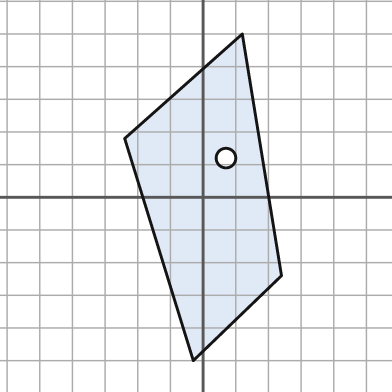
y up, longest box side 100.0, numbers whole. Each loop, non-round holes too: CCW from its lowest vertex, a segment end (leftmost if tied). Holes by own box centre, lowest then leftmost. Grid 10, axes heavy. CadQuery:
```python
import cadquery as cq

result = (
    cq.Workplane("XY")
    .moveTo(-3.0, -50.0)
    .lineTo(24.0, -24.0)
    .lineTo(12.0, 50.0)
    .lineTo(-24.0, 18.0)
    .close()
    .moveTo(7.0, 12.0)
    .circle(3.0)
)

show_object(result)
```